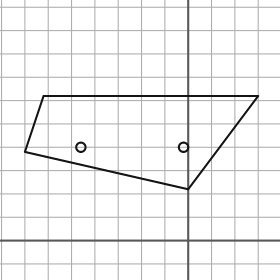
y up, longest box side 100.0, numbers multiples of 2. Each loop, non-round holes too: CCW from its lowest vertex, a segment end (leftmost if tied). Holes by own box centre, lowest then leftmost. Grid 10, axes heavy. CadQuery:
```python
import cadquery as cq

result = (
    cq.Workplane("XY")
    .moveTo(0.0, 22.0)
    .lineTo(30.0, 62.0)
    .lineTo(-62.0, 62.0)
    .lineTo(-70.0, 38.0)
    .close()
    .moveTo(-46.0, 40.0)
    .circle(2.0)
    .moveTo(-2.0, 40.0)
    .circle(2.0)
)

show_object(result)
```